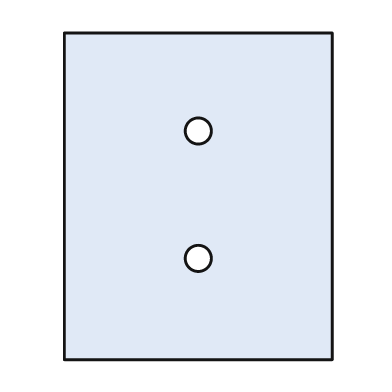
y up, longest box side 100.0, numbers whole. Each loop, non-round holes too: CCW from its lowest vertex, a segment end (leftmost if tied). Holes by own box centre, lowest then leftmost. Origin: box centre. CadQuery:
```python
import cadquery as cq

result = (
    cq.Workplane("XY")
    .moveTo(-41.0, -50.0)
    .lineTo(41.0, -50.0)
    .lineTo(41.0, 50.0)
    .lineTo(-41.0, 50.0)
    .close()
    .moveTo(0.0, -19.0)
    .circle(4.0)
    .moveTo(0.0, 20.0)
    .circle(4.0)
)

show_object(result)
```